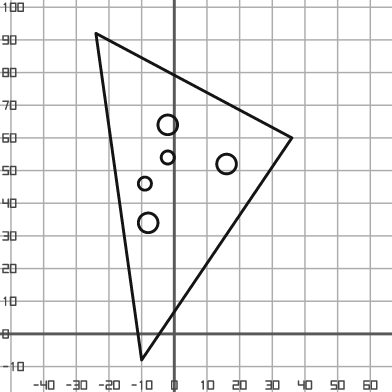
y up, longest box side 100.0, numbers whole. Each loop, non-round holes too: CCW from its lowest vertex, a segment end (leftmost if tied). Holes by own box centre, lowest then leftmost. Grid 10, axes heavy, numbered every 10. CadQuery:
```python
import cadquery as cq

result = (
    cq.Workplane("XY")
    .moveTo(-10.0, -8.0)
    .lineTo(36.0, 60.0)
    .lineTo(-24.0, 92.0)
    .close()
    .moveTo(-8.0, 34.0)
    .circle(3.0)
    .moveTo(-9.0, 46.0)
    .circle(2.0)
    .moveTo(16.0, 52.0)
    .circle(3.0)
    .moveTo(-2.0, 54.0)
    .circle(2.0)
    .moveTo(-2.0, 64.0)
    .circle(3.0)
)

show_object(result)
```